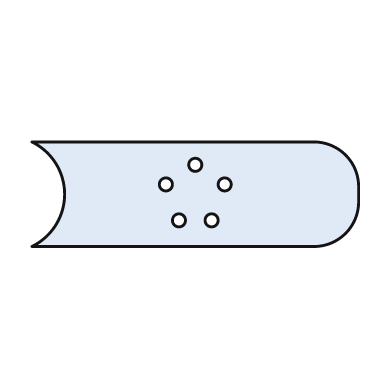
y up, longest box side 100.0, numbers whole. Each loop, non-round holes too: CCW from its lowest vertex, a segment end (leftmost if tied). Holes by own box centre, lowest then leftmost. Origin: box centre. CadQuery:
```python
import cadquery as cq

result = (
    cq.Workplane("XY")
    .moveTo(-50.0, -16.0)
    .lineTo(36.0, -16.0)
    .threePointArc((46.0, -12.0), (50.0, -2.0))
    .lineTo(50.0, 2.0)
    .threePointArc((46.0, 12.0), (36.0, 16.0))
    .lineTo(-50.0, 16.0)
    .threePointArc((-40.0, 0.0), (-50.0, -16.0))
    .close()
    .moveTo(-5.0, -8.0)
    .circle(2.0)
    .moveTo(5.0, -8.0)
    .circle(2.0)
    .moveTo(-9.0, 3.0)
    .circle(2.0)
    .moveTo(9.0, 3.0)
    .circle(2.0)
    .moveTo(0.0, 9.0)
    .circle(2.0)
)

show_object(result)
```